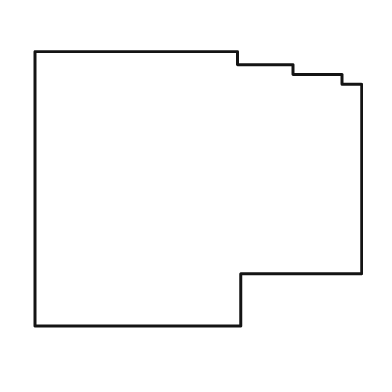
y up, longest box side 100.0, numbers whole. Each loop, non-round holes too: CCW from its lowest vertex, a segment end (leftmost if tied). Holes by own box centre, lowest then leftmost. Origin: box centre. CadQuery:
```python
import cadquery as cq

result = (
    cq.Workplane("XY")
    .moveTo(-50.0, -42.0)
    .lineTo(13.0, -42.0)
    .lineTo(13.0, -26.0)
    .lineTo(50.0, -26.0)
    .lineTo(50.0, 32.0)
    .lineTo(44.0, 32.0)
    .lineTo(44.0, 35.0)
    .lineTo(29.0, 35.0)
    .lineTo(29.0, 38.0)
    .lineTo(12.0, 38.0)
    .lineTo(12.0, 42.0)
    .lineTo(-50.0, 42.0)
    .close()
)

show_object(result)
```